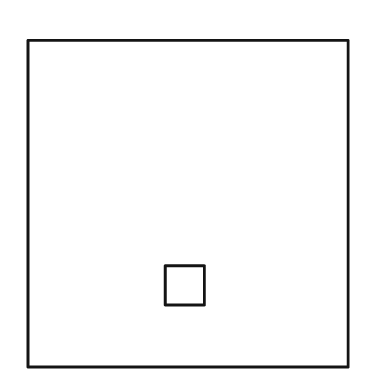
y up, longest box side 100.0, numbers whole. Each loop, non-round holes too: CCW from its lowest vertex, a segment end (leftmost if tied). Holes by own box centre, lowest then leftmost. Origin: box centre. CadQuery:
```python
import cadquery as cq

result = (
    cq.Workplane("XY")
    .moveTo(-49.0, -50.0)
    .lineTo(49.0, -50.0)
    .lineTo(49.0, 50.0)
    .lineTo(-49.0, 50.0)
    .close()
    .moveTo(-7.0, -31.0)
    .lineTo(5.0, -31.0)
    .lineTo(5.0, -19.0)
    .lineTo(-7.0, -19.0)
    .close()
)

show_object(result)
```